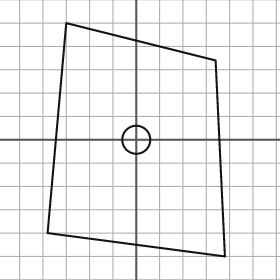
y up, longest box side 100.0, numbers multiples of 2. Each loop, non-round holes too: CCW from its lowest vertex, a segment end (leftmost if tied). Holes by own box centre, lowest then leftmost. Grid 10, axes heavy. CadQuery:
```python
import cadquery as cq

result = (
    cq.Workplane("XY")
    .moveTo(38.0, -50.0)
    .lineTo(34.0, 34.0)
    .lineTo(-30.0, 50.0)
    .lineTo(-38.0, -40.0)
    .close()
    .moveTo(0.0, 0.0)
    .circle(6.0)
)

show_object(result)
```